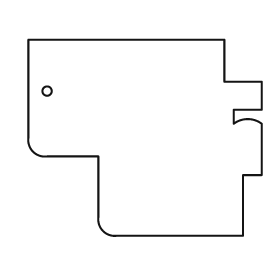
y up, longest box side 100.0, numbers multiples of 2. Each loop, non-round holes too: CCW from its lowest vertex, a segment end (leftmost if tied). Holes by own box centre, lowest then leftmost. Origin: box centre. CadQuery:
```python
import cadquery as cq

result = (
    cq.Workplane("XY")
    .moveTo(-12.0, -42.0)
    .lineTo(42.0, -42.0)
    .lineTo(42.0, -16.0)
    .lineTo(50.0, -16.0)
    .lineTo(50.0, 6.0)
    .threePointArc((44.0, 8.0), (38.0, 6.0))
    .lineTo(38.0, 12.0)
    .lineTo(50.0, 12.0)
    .lineTo(50.0, 24.0)
    .lineTo(34.0, 24.0)
    .lineTo(34.0, 42.0)
    .lineTo(-50.0, 42.0)
    .lineTo(-50.0, 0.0)
    .threePointArc((-48.0, -6.0), (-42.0, -8.0))
    .lineTo(-20.0, -8.0)
    .lineTo(-20.0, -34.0)
    .threePointArc((-18.0, -40.0), (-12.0, -42.0))
    .close()
    .moveTo(-42.0, 20.0)
    .circle(2.0)
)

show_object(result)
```